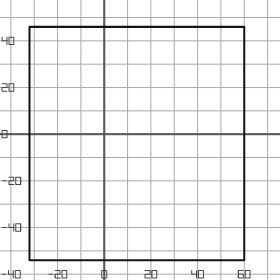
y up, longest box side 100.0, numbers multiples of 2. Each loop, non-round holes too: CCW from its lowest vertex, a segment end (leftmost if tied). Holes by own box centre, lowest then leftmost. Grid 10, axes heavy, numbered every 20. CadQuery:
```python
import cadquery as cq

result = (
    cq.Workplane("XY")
    .moveTo(-32.0, -54.0)
    .lineTo(60.0, -54.0)
    .lineTo(60.0, 46.0)
    .lineTo(-32.0, 46.0)
    .close()
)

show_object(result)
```